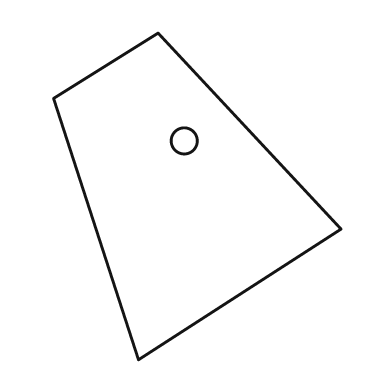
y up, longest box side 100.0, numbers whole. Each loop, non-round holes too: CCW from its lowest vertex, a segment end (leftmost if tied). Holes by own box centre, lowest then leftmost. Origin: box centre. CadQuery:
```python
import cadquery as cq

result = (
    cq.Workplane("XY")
    .moveTo(-18.0, -50.0)
    .lineTo(44.0, -10.0)
    .lineTo(-12.0, 50.0)
    .lineTo(-44.0, 30.0)
    .close()
    .moveTo(-4.0, 17.0)
    .circle(4.0)
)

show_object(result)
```